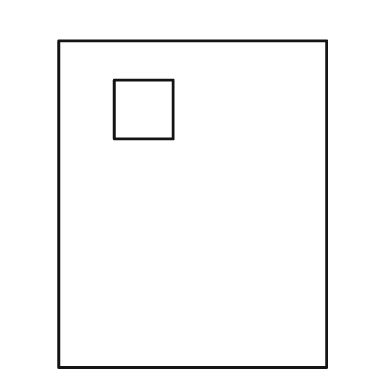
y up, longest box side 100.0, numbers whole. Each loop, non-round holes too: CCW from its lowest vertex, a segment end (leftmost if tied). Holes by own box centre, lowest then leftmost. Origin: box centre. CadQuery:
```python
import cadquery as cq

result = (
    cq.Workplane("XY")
    .moveTo(-41.0, -50.0)
    .lineTo(41.0, -50.0)
    .lineTo(41.0, 50.0)
    .lineTo(-41.0, 50.0)
    .close()
    .moveTo(-24.0, 20.0)
    .lineTo(-6.0, 20.0)
    .lineTo(-6.0, 38.0)
    .lineTo(-24.0, 38.0)
    .close()
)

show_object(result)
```